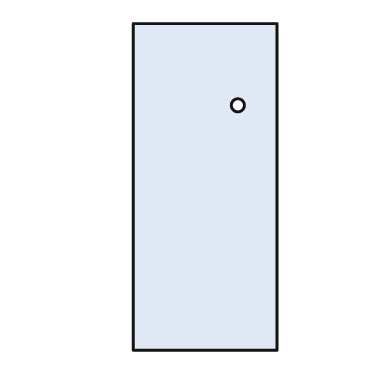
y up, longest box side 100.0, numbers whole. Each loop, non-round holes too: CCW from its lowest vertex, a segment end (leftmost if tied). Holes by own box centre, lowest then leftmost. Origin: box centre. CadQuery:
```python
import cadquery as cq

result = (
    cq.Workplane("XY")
    .moveTo(-22.0, -50.0)
    .lineTo(22.0, -50.0)
    .lineTo(22.0, 50.0)
    .lineTo(-22.0, 50.0)
    .close()
    .moveTo(10.0, 25.0)
    .circle(2.0)
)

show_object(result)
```